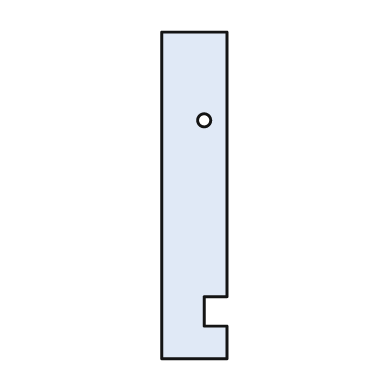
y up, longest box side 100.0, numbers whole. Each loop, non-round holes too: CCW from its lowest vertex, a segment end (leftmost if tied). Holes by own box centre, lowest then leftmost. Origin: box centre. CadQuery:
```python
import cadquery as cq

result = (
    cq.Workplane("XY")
    .moveTo(-10.0, -50.0)
    .lineTo(10.0, -50.0)
    .lineTo(10.0, -40.0)
    .lineTo(3.0, -40.0)
    .lineTo(3.0, -31.0)
    .lineTo(10.0, -31.0)
    .lineTo(10.0, 50.0)
    .lineTo(-10.0, 50.0)
    .close()
    .moveTo(3.0, 23.0)
    .circle(2.0)
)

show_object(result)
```